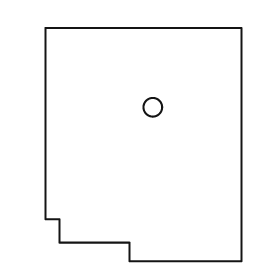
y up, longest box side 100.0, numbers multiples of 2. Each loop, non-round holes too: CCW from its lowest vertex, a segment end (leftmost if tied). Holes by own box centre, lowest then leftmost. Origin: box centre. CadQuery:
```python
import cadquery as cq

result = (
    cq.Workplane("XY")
    .moveTo(-6.0, -50.0)
    .lineTo(42.0, -50.0)
    .lineTo(42.0, 50.0)
    .lineTo(-42.0, 50.0)
    .lineTo(-42.0, -32.0)
    .lineTo(-36.0, -32.0)
    .lineTo(-36.0, -42.0)
    .lineTo(-6.0, -42.0)
    .close()
    .moveTo(4.0, 16.0)
    .circle(4.0)
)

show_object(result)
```